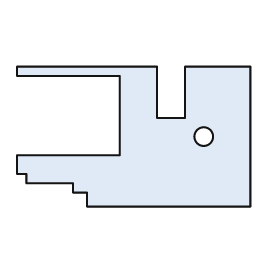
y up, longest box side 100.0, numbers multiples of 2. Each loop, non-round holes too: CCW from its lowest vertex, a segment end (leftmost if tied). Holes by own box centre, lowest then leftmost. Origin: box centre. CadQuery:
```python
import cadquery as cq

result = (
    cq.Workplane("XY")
    .moveTo(-20.0, -30.0)
    .lineTo(50.0, -30.0)
    .lineTo(50.0, 30.0)
    .lineTo(22.0, 30.0)
    .lineTo(22.0, 8.0)
    .lineTo(10.0, 8.0)
    .lineTo(10.0, 30.0)
    .lineTo(-50.0, 30.0)
    .lineTo(-50.0, 26.0)
    .lineTo(-6.0, 26.0)
    .lineTo(-6.0, -8.0)
    .lineTo(-50.0, -8.0)
    .lineTo(-50.0, -16.0)
    .lineTo(-46.0, -16.0)
    .lineTo(-46.0, -20.0)
    .lineTo(-26.0, -20.0)
    .lineTo(-26.0, -24.0)
    .lineTo(-20.0, -24.0)
    .close()
    .moveTo(30.0, 0.0)
    .circle(4.0)
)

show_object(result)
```